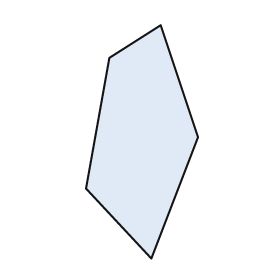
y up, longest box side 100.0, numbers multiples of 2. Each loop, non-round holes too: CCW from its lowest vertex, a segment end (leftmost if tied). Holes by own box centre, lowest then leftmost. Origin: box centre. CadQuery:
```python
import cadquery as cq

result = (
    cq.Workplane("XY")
    .moveTo(4.0, -50.0)
    .lineTo(24.0, 2.0)
    .lineTo(8.0, 50.0)
    .lineTo(-14.0, 36.0)
    .lineTo(-24.0, -20.0)
    .close()
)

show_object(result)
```